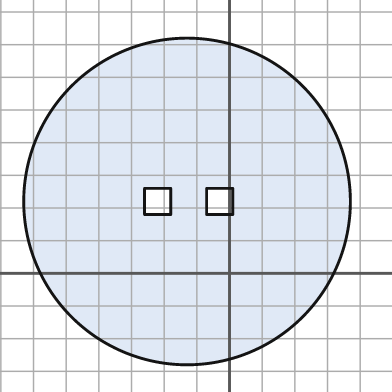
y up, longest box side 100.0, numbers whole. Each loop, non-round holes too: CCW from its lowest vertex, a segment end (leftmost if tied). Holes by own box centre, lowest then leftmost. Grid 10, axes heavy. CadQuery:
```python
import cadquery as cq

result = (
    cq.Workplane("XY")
    .moveTo(-13.0, 22.0)
    .circle(50.0)
    .moveTo(-26.0, 18.0)
    .lineTo(-18.0, 18.0)
    .lineTo(-18.0, 26.0)
    .lineTo(-26.0, 26.0)
    .close()
    .moveTo(-7.0, 18.0)
    .lineTo(1.0, 18.0)
    .lineTo(1.0, 26.0)
    .lineTo(-7.0, 26.0)
    .close()
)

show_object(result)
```